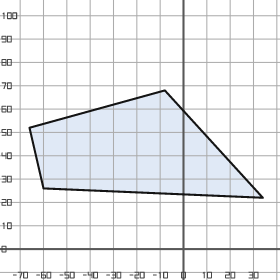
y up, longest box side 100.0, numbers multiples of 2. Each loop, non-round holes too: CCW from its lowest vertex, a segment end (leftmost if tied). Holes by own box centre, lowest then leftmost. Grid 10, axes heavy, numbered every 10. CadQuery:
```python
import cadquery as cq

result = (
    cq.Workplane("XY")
    .moveTo(34.0, 22.0)
    .lineTo(-8.0, 68.0)
    .lineTo(-66.0, 52.0)
    .lineTo(-60.0, 26.0)
    .close()
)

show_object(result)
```